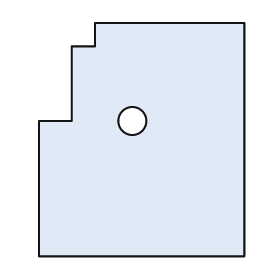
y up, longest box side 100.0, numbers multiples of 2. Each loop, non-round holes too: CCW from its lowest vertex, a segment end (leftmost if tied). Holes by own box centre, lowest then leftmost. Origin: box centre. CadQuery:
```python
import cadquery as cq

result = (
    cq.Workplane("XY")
    .moveTo(-44.0, -50.0)
    .lineTo(44.0, -50.0)
    .lineTo(44.0, 50.0)
    .lineTo(-20.0, 50.0)
    .lineTo(-20.0, 40.0)
    .lineTo(-30.0, 40.0)
    .lineTo(-30.0, 8.0)
    .lineTo(-44.0, 8.0)
    .close()
    .moveTo(-4.0, 8.0)
    .circle(6.0)
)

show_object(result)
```